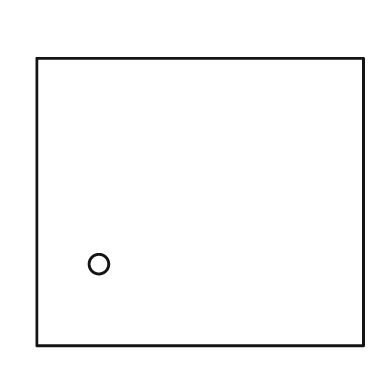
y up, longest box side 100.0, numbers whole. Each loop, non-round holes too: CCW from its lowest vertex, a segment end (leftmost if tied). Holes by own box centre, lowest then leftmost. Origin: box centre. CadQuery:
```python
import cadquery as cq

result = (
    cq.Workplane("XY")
    .moveTo(-50.0, -44.0)
    .lineTo(50.0, -44.0)
    .lineTo(50.0, 44.0)
    .lineTo(-50.0, 44.0)
    .close()
    .moveTo(-31.0, -19.0)
    .circle(3.0)
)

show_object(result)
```